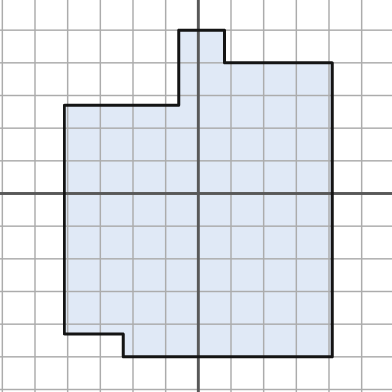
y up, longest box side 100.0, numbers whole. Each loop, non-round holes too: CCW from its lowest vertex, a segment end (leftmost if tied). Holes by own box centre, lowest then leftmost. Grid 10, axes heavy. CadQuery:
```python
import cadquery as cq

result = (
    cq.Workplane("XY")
    .moveTo(-23.0, -50.0)
    .lineTo(41.0, -50.0)
    .lineTo(41.0, 40.0)
    .lineTo(8.0, 40.0)
    .lineTo(8.0, 50.0)
    .lineTo(-6.0, 50.0)
    .lineTo(-6.0, 27.0)
    .lineTo(-41.0, 27.0)
    .lineTo(-41.0, -43.0)
    .lineTo(-23.0, -43.0)
    .close()
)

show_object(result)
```